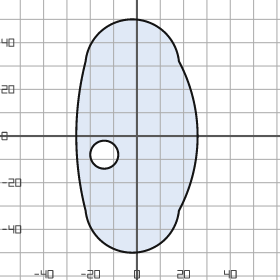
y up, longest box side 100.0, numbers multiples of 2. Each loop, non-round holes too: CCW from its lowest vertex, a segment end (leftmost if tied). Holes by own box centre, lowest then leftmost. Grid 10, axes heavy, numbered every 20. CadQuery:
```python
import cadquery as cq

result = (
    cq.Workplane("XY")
    .moveTo(-22.0, -32.0)
    .threePointArc((-2.0, -50.0), (18.0, -32.0))
    .threePointArc((26.0, 0.0), (18.0, 32.0))
    .threePointArc((-2.0, 50.0), (-22.0, 32.0))
    .threePointArc((-26.0, 0.0), (-22.0, -32.0))
    .close()
    .moveTo(-14.0, -8.0)
    .circle(6.0)
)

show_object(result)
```